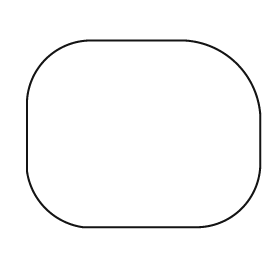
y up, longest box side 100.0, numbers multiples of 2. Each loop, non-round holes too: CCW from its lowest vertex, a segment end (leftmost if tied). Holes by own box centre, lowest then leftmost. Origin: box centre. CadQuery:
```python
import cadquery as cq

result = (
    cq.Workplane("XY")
    .moveTo(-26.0, -40.0)
    .lineTo(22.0, -40.0)
    .threePointArc((42.0, -32.0), (50.0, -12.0))
    .lineTo(50.0, 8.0)
    .threePointArc((40.0, 30.0), (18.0, 40.0))
    .lineTo(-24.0, 40.0)
    .threePointArc((-42.0, 32.0), (-50.0, 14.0))
    .lineTo(-50.0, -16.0)
    .threePointArc((-42.0, -32.0), (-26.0, -40.0))
    .close()
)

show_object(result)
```